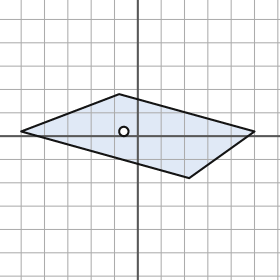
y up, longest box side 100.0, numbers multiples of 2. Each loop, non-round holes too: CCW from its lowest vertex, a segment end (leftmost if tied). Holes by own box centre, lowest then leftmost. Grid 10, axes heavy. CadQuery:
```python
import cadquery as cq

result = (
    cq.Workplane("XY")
    .moveTo(22.0, -18.0)
    .lineTo(50.0, 2.0)
    .lineTo(-8.0, 18.0)
    .lineTo(-50.0, 2.0)
    .close()
    .moveTo(-6.0, 2.0)
    .circle(2.0)
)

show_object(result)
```